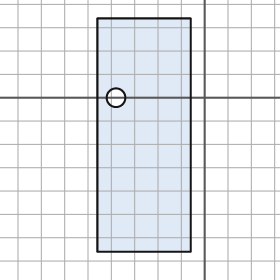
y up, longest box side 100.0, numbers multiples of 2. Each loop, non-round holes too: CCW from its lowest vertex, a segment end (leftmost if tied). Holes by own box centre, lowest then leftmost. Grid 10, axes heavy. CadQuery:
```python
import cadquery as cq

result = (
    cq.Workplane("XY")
    .moveTo(-46.0, -66.0)
    .lineTo(-6.0, -66.0)
    .lineTo(-6.0, 34.0)
    .lineTo(-46.0, 34.0)
    .close()
    .moveTo(-38.0, 0.0)
    .circle(4.0)
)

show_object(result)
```